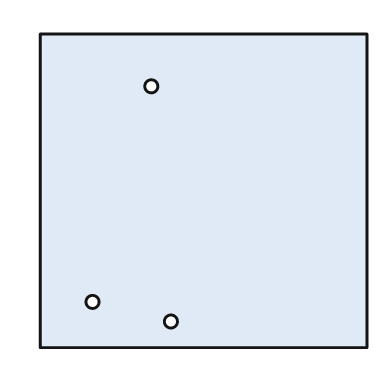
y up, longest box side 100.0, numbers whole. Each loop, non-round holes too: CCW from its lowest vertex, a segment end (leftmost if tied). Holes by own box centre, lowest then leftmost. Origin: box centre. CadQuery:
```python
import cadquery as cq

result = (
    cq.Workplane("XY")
    .moveTo(-50.0, -48.0)
    .lineTo(50.0, -48.0)
    .lineTo(50.0, 48.0)
    .lineTo(-50.0, 48.0)
    .close()
    .moveTo(-10.0, -40.0)
    .circle(2.0)
    .moveTo(-34.0, -34.0)
    .circle(2.0)
    .moveTo(-16.0, 32.0)
    .circle(2.0)
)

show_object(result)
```